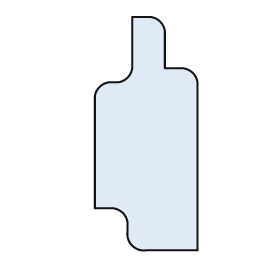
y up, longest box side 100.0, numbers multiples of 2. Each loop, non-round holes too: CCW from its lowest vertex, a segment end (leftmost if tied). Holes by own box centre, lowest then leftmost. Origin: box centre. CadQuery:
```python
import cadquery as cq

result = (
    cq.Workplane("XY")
    .moveTo(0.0, -50.0)
    .lineTo(22.0, -50.0)
    .lineTo(22.0, 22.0)
    .threePointArc((20.0, 26.0), (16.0, 28.0))
    .lineTo(8.0, 28.0)
    .lineTo(8.0, 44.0)
    .threePointArc((6.0, 48.0), (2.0, 50.0))
    .lineTo(-6.0, 50.0)
    .lineTo(-6.0, 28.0)
    .threePointArc((-8.0, 24.0), (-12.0, 22.0))
    .lineTo(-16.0, 22.0)
    .threePointArc((-20.0, 20.0), (-22.0, 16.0))
    .lineTo(-22.0, -32.0)
    .lineTo(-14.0, -32.0)
    .threePointArc((-10.0, -34.0), (-8.0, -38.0))
    .lineTo(-8.0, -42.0)
    .threePointArc((-6.0, -48.0), (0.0, -50.0))
    .close()
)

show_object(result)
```